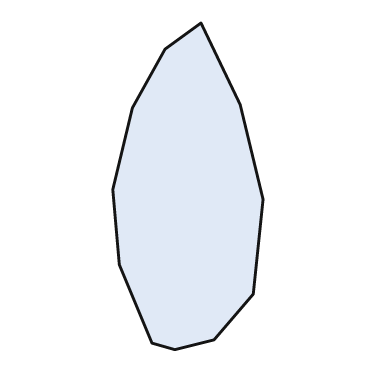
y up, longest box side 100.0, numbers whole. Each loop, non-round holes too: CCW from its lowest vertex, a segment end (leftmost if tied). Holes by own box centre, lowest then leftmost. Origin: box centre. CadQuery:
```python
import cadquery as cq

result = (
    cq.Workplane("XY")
    .moveTo(-4.0, -50.0)
    .lineTo(8.0, -47.0)
    .lineTo(20.0, -33.0)
    .lineTo(23.0, -4.0)
    .lineTo(16.0, 25.0)
    .lineTo(4.0, 50.0)
    .lineTo(-7.0, 42.0)
    .lineTo(-17.0, 24.0)
    .lineTo(-23.0, -1.0)
    .lineTo(-21.0, -24.0)
    .lineTo(-11.0, -48.0)
    .close()
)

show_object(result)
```